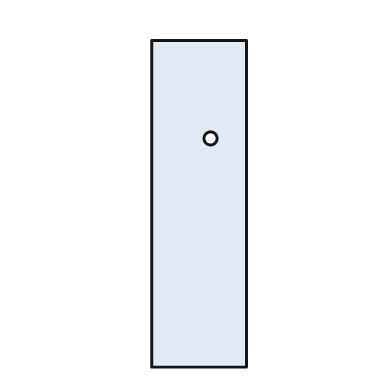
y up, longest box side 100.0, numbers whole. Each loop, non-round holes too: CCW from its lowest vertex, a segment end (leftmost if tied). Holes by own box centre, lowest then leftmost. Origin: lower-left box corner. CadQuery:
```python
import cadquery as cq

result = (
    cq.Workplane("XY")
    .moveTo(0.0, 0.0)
    .lineTo(29.0, 0.0)
    .lineTo(29.0, 100.0)
    .lineTo(0.0, 100.0)
    .close()
    .moveTo(18.0, 70.0)
    .circle(2.0)
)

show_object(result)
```